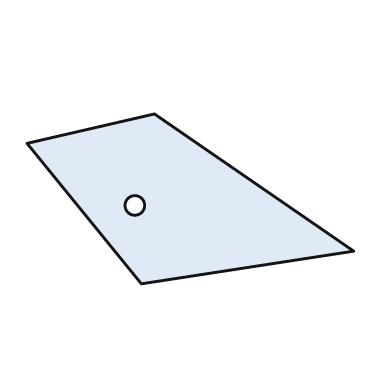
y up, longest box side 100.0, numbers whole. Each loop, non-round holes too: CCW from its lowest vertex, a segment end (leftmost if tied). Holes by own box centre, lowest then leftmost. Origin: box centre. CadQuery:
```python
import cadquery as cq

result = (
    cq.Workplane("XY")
    .moveTo(-15.0, -26.0)
    .lineTo(50.0, -16.0)
    .lineTo(-11.0, 26.0)
    .lineTo(-50.0, 17.0)
    .close()
    .moveTo(-17.0, -2.0)
    .circle(3.0)
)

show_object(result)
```